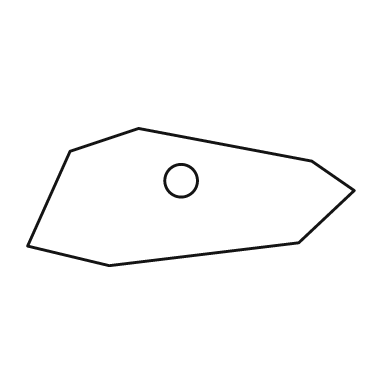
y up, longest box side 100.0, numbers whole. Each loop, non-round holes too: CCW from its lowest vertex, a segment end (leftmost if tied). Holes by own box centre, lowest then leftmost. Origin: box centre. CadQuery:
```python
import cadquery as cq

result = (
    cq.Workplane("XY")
    .moveTo(-25.0, -21.0)
    .lineTo(33.0, -14.0)
    .lineTo(50.0, 2.0)
    .lineTo(37.0, 11.0)
    .lineTo(-16.0, 21.0)
    .lineTo(-37.0, 14.0)
    .lineTo(-50.0, -15.0)
    .close()
    .moveTo(-3.0, 5.0)
    .circle(5.0)
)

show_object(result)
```